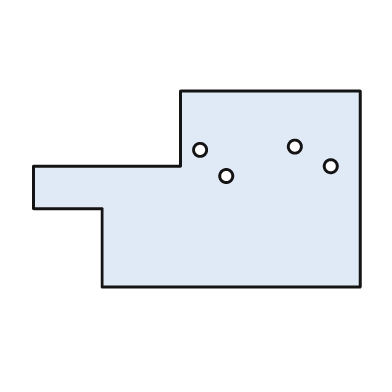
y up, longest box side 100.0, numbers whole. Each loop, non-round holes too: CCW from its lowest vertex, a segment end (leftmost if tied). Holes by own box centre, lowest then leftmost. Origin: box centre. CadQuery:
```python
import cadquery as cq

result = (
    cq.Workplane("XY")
    .moveTo(-29.0, -30.0)
    .lineTo(50.0, -30.0)
    .lineTo(50.0, 30.0)
    .lineTo(-5.0, 30.0)
    .lineTo(-5.0, 7.0)
    .lineTo(-50.0, 7.0)
    .lineTo(-50.0, -6.0)
    .lineTo(-29.0, -6.0)
    .close()
    .moveTo(9.0, 4.0)
    .circle(2.0)
    .moveTo(41.0, 7.0)
    .circle(2.0)
    .moveTo(1.0, 12.0)
    .circle(2.0)
    .moveTo(30.0, 13.0)
    .circle(2.0)
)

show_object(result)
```